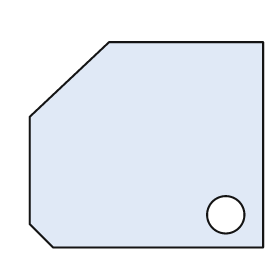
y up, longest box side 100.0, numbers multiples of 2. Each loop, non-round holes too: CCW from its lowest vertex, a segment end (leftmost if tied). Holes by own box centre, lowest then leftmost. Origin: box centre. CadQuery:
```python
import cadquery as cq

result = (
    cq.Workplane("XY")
    .moveTo(-40.0, -44.0)
    .lineTo(50.0, -44.0)
    .lineTo(50.0, 44.0)
    .lineTo(-16.0, 44.0)
    .lineTo(-50.0, 12.0)
    .lineTo(-50.0, -34.0)
    .close()
    .moveTo(34.0, -30.0)
    .circle(8.0)
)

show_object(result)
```